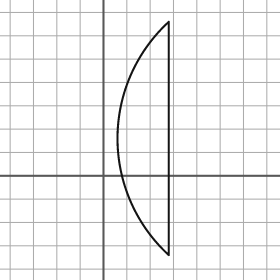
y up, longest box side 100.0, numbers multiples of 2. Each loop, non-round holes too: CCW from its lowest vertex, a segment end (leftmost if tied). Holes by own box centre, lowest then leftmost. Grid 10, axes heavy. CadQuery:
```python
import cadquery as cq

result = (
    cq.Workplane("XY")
    .moveTo(28.0, -34.0)
    .lineTo(28.0, 66.0)
    .threePointArc((6.0, 16.0), (28.0, -34.0))
    .close()
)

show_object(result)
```